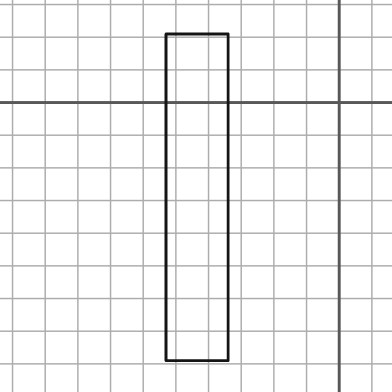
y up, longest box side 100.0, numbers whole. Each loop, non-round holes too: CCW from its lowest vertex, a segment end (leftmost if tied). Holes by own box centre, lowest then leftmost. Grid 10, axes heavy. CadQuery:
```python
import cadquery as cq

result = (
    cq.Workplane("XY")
    .moveTo(-53.0, -79.0)
    .lineTo(-34.0, -79.0)
    .lineTo(-34.0, 21.0)
    .lineTo(-53.0, 21.0)
    .close()
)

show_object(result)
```